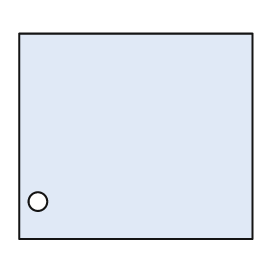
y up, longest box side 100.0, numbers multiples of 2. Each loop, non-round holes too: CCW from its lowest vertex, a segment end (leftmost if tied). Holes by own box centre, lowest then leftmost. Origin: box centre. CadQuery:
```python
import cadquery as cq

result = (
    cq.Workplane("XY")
    .moveTo(-50.0, -44.0)
    .lineTo(50.0, -44.0)
    .lineTo(50.0, 44.0)
    .lineTo(-50.0, 44.0)
    .close()
    .moveTo(-42.0, -28.0)
    .circle(4.0)
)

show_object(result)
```